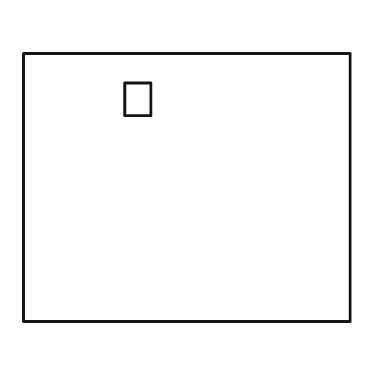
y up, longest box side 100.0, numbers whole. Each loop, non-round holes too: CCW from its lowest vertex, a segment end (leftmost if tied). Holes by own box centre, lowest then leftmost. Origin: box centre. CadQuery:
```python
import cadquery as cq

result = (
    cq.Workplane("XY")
    .moveTo(-50.0, -41.0)
    .lineTo(50.0, -41.0)
    .lineTo(50.0, 41.0)
    .lineTo(-50.0, 41.0)
    .close()
    .moveTo(-19.0, 22.0)
    .lineTo(-11.0, 22.0)
    .lineTo(-11.0, 32.0)
    .lineTo(-19.0, 32.0)
    .close()
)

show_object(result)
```